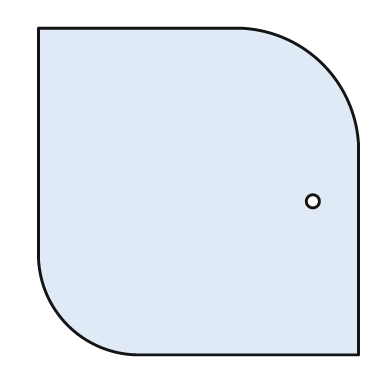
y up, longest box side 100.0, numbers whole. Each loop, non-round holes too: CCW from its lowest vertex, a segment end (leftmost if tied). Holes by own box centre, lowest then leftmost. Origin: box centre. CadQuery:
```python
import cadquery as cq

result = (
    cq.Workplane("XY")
    .moveTo(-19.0, -50.0)
    .lineTo(49.0, -50.0)
    .lineTo(49.0, 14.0)
    .threePointArc((38.0, 39.0), (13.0, 50.0))
    .lineTo(-49.0, 50.0)
    .lineTo(-49.0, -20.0)
    .threePointArc((-40.0, -41.0), (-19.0, -50.0))
    .close()
    .moveTo(35.0, -3.0)
    .circle(2.0)
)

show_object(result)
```